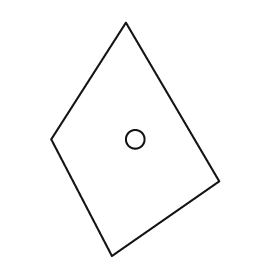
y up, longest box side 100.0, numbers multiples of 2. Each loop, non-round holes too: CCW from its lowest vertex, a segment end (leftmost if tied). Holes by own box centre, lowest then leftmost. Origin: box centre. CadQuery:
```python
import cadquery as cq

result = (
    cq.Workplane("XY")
    .moveTo(-10.0, -50.0)
    .lineTo(36.0, -18.0)
    .lineTo(-4.0, 50.0)
    .lineTo(-36.0, 0.0)
    .close()
    .moveTo(0.0, 0.0)
    .circle(4.0)
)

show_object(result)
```